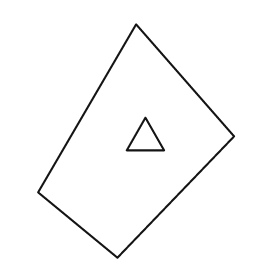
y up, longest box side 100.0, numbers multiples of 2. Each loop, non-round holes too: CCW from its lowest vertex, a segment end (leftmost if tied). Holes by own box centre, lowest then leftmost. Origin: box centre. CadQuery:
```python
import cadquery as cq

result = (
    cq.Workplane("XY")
    .moveTo(-8.0, -50.0)
    .lineTo(42.0, 2.0)
    .lineTo(0.0, 50.0)
    .lineTo(-42.0, -22.0)
    .close()
    .moveTo(-4.0, -4.0)
    .lineTo(12.0, -4.0)
    .lineTo(4.0, 10.0)
    .close()
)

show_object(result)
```